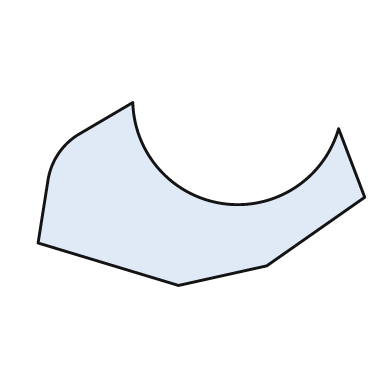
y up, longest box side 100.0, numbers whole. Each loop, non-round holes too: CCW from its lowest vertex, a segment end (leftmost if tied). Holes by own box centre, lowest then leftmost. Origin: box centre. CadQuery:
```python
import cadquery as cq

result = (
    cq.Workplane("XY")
    .moveTo(-7.0, -28.0)
    .lineTo(20.0, -22.0)
    .lineTo(50.0, -1.0)
    .lineTo(42.0, 20.0)
    .threePointArc((7.0, -3.0), (-21.0, 28.0))
    .lineTo(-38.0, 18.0)
    .threePointArc((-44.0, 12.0), (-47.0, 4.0))
    .lineTo(-50.0, -15.0)
    .close()
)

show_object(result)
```